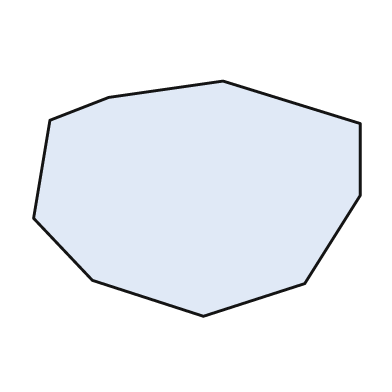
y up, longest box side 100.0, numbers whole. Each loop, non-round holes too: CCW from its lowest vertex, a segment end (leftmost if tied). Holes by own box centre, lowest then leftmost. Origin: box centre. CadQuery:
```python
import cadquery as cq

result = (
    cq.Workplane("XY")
    .moveTo(2.0, -36.0)
    .lineTo(33.0, -26.0)
    .lineTo(50.0, 1.0)
    .lineTo(50.0, 23.0)
    .lineTo(8.0, 36.0)
    .lineTo(-27.0, 31.0)
    .lineTo(-45.0, 24.0)
    .lineTo(-50.0, -6.0)
    .lineTo(-32.0, -25.0)
    .close()
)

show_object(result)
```